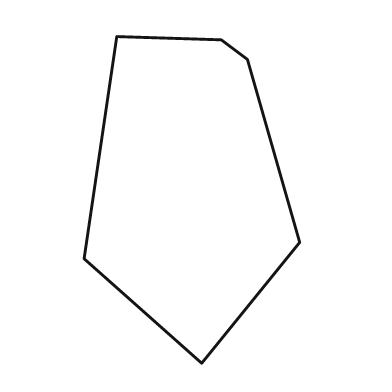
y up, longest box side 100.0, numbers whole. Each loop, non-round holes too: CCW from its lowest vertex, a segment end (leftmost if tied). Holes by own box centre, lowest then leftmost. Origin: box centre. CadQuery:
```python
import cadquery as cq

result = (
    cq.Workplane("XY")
    .moveTo(3.0, -50.0)
    .lineTo(33.0, -13.0)
    .lineTo(17.0, 43.0)
    .lineTo(9.0, 49.0)
    .lineTo(-23.0, 50.0)
    .lineTo(-33.0, -18.0)
    .close()
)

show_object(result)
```